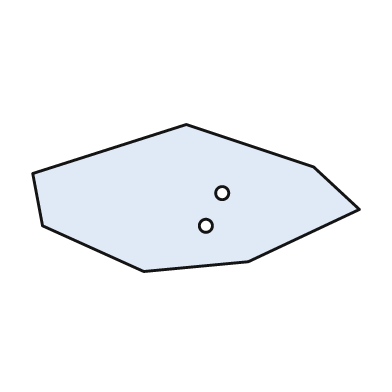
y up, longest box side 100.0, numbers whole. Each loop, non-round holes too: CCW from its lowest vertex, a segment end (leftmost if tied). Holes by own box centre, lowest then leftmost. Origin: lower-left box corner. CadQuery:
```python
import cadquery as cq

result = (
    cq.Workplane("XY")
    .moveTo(34.0, 0.0)
    .lineTo(66.0, 3.0)
    .lineTo(100.0, 19.0)
    .lineTo(86.0, 32.0)
    .lineTo(47.0, 45.0)
    .lineTo(0.0, 30.0)
    .lineTo(3.0, 14.0)
    .close()
    .moveTo(53.0, 14.0)
    .circle(2.0)
    .moveTo(58.0, 24.0)
    .circle(2.0)
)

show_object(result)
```